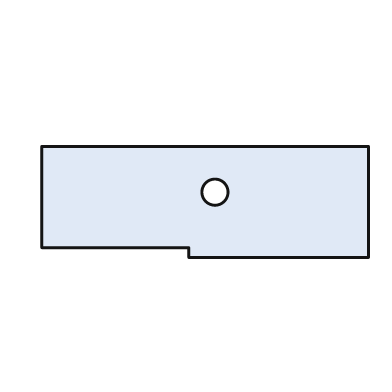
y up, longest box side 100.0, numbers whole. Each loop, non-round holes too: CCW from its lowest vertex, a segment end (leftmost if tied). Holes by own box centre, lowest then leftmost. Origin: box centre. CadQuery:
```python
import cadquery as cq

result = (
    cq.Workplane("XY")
    .moveTo(-5.0, -17.0)
    .lineTo(50.0, -17.0)
    .lineTo(50.0, 17.0)
    .lineTo(-50.0, 17.0)
    .lineTo(-50.0, -14.0)
    .lineTo(-5.0, -14.0)
    .close()
    .moveTo(3.0, 3.0)
    .circle(4.0)
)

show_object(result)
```